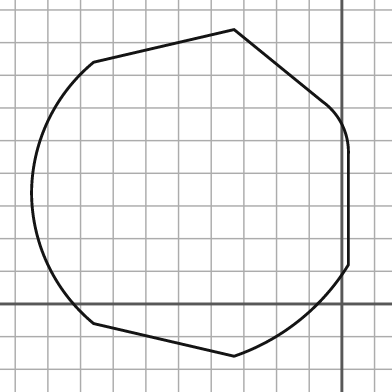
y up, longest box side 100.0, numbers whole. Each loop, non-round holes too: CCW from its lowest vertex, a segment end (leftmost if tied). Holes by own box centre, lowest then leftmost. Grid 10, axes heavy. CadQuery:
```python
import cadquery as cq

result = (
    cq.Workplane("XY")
    .moveTo(-33.0, -16.0)
    .threePointArc((-13.0, -5.0), (2.0, 12.0))
    .lineTo(2.0, 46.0)
    .threePointArc((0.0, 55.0), (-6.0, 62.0))
    .lineTo(-33.0, 84.0)
    .lineTo(-76.0, 74.0)
    .threePointArc((-90.0, 56.0), (-95.0, 34.0))
    .threePointArc((-90.0, 12.0), (-76.0, -6.0))
    .close()
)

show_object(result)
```